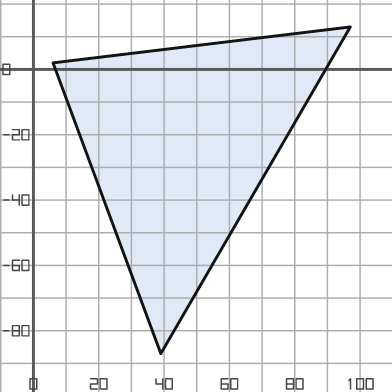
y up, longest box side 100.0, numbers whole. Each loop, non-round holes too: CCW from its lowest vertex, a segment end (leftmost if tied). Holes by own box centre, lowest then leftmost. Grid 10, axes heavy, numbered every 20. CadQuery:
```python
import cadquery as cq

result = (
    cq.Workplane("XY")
    .moveTo(39.0, -87.0)
    .lineTo(97.0, 13.0)
    .lineTo(6.0, 2.0)
    .close()
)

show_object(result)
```